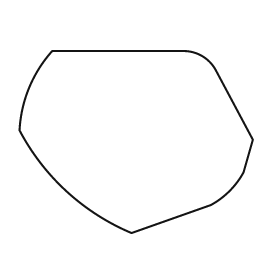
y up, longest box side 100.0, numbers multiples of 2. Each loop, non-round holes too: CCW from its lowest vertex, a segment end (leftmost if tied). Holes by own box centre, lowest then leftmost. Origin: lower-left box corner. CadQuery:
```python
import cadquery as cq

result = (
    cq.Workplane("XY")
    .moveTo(48.0, 0.0)
    .lineTo(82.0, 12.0)
    .threePointArc((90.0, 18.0), (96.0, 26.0))
    .lineTo(100.0, 40.0)
    .lineTo(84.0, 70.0)
    .threePointArc((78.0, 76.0), (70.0, 78.0))
    .lineTo(14.0, 78.0)
    .threePointArc((4.0, 62.0), (0.0, 44.0))
    .threePointArc((20.0, 18.0), (48.0, 0.0))
    .close()
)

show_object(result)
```